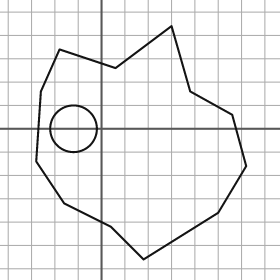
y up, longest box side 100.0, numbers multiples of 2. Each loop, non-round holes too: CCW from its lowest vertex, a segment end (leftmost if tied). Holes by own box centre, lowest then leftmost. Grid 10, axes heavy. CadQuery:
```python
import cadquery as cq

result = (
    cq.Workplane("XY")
    .moveTo(18.0, -56.0)
    .lineTo(50.0, -36.0)
    .lineTo(62.0, -16.0)
    .lineTo(56.0, 6.0)
    .lineTo(38.0, 16.0)
    .lineTo(30.0, 44.0)
    .lineTo(6.0, 26.0)
    .lineTo(-18.0, 34.0)
    .lineTo(-26.0, 16.0)
    .lineTo(-28.0, -14.0)
    .lineTo(-16.0, -32.0)
    .lineTo(4.0, -42.0)
    .close()
    .moveTo(-12.0, 0.0)
    .circle(10.0)
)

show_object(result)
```